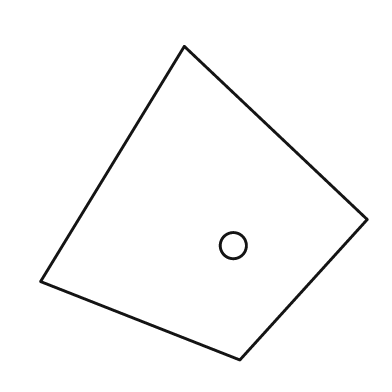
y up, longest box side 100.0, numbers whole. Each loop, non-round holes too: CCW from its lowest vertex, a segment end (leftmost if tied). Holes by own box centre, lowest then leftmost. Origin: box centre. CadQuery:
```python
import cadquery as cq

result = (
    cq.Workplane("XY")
    .moveTo(11.0, -48.0)
    .lineTo(50.0, -5.0)
    .lineTo(-6.0, 48.0)
    .lineTo(-50.0, -24.0)
    .close()
    .moveTo(9.0, -13.0)
    .circle(4.0)
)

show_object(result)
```